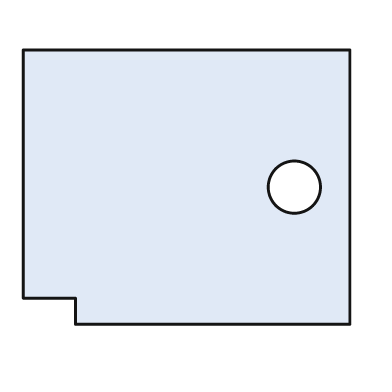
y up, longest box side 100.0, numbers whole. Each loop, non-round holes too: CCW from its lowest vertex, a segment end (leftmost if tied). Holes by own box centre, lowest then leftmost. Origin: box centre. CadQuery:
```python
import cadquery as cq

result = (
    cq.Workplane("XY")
    .moveTo(-34.0, -42.0)
    .lineTo(50.0, -42.0)
    .lineTo(50.0, 42.0)
    .lineTo(-50.0, 42.0)
    .lineTo(-50.0, -34.0)
    .lineTo(-34.0, -34.0)
    .close()
    .moveTo(33.0, 0.0)
    .circle(8.0)
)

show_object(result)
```